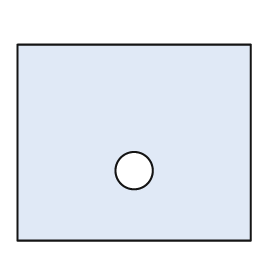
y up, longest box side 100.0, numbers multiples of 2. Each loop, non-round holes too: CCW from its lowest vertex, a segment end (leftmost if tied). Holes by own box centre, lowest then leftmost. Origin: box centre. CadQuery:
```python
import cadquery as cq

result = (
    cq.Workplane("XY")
    .moveTo(-50.0, -42.0)
    .lineTo(50.0, -42.0)
    .lineTo(50.0, 42.0)
    .lineTo(-50.0, 42.0)
    .close()
    .moveTo(0.0, -12.0)
    .circle(8.0)
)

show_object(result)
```